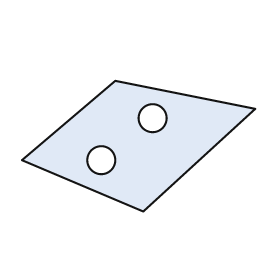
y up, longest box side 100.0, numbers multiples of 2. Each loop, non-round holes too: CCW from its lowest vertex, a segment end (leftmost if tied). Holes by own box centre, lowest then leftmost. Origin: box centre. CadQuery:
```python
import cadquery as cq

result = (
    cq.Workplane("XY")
    .moveTo(2.0, -28.0)
    .lineTo(50.0, 16.0)
    .lineTo(-10.0, 28.0)
    .lineTo(-50.0, -6.0)
    .close()
    .moveTo(-16.0, -6.0)
    .circle(6.0)
    .moveTo(6.0, 12.0)
    .circle(6.0)
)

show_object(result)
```